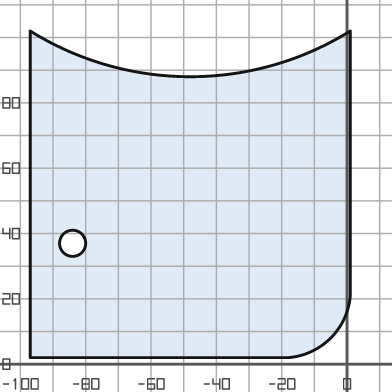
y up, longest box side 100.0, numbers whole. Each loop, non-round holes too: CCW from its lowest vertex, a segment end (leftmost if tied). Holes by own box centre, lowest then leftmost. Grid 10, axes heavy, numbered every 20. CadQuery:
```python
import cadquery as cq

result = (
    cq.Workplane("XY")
    .moveTo(-97.0, 2.0)
    .lineTo(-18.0, 2.0)
    .threePointArc((-5.0, 8.0), (1.0, 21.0))
    .lineTo(1.0, 102.0)
    .threePointArc((-48.0, 88.0), (-97.0, 102.0))
    .close()
    .moveTo(-84.0, 37.0)
    .circle(4.0)
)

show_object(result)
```